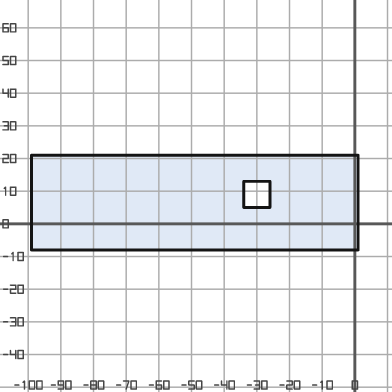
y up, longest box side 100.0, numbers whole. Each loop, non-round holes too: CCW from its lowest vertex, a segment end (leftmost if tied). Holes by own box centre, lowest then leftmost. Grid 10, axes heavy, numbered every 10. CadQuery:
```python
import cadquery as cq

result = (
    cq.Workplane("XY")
    .moveTo(-99.0, -8.0)
    .lineTo(1.0, -8.0)
    .lineTo(1.0, 21.0)
    .lineTo(-99.0, 21.0)
    .close()
    .moveTo(-34.0, 5.0)
    .lineTo(-26.0, 5.0)
    .lineTo(-26.0, 13.0)
    .lineTo(-34.0, 13.0)
    .close()
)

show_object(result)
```